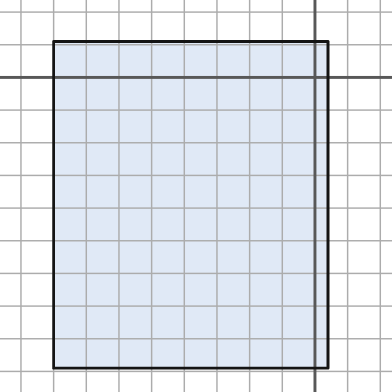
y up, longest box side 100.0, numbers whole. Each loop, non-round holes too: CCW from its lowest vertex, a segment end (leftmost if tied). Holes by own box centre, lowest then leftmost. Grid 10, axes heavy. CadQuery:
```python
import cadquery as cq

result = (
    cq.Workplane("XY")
    .moveTo(-80.0, -89.0)
    .lineTo(4.0, -89.0)
    .lineTo(4.0, 11.0)
    .lineTo(-80.0, 11.0)
    .close()
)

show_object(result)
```